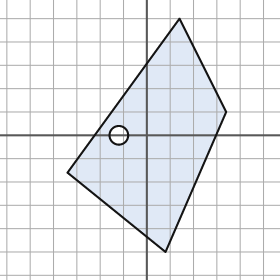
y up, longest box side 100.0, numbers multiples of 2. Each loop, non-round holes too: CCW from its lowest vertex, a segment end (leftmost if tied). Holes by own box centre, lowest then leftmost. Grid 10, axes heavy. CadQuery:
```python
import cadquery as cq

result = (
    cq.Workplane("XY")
    .moveTo(8.0, -50.0)
    .lineTo(34.0, 10.0)
    .lineTo(14.0, 50.0)
    .lineTo(-34.0, -16.0)
    .close()
    .moveTo(-12.0, 0.0)
    .circle(4.0)
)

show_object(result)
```